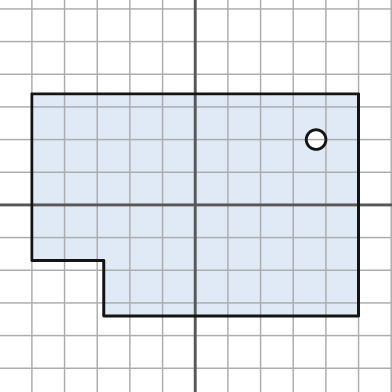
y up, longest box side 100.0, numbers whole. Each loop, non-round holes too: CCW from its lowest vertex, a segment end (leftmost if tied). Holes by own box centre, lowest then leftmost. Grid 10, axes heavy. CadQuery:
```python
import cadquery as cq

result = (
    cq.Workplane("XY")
    .moveTo(-28.0, -34.0)
    .lineTo(50.0, -34.0)
    .lineTo(50.0, 34.0)
    .lineTo(-50.0, 34.0)
    .lineTo(-50.0, -17.0)
    .lineTo(-28.0, -17.0)
    .close()
    .moveTo(37.0, 20.0)
    .circle(3.0)
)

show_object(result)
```